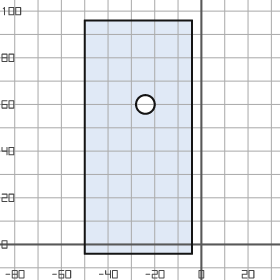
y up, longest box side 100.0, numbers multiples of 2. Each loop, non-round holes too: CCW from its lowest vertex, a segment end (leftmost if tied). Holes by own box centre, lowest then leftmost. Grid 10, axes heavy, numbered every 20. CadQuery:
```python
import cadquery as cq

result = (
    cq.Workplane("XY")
    .moveTo(-50.0, -4.0)
    .lineTo(-4.0, -4.0)
    .lineTo(-4.0, 96.0)
    .lineTo(-50.0, 96.0)
    .close()
    .moveTo(-24.0, 60.0)
    .circle(4.0)
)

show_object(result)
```